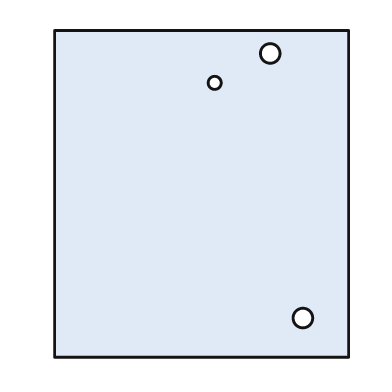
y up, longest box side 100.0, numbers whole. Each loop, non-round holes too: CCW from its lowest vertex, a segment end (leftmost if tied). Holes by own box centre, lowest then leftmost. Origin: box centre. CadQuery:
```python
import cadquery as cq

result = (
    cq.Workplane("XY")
    .moveTo(-45.0, -50.0)
    .lineTo(45.0, -50.0)
    .lineTo(45.0, 50.0)
    .lineTo(-45.0, 50.0)
    .close()
    .moveTo(31.0, -38.0)
    .circle(3.0)
    .moveTo(4.0, 34.0)
    .circle(2.0)
    .moveTo(21.0, 43.0)
    .circle(3.0)
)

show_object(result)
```